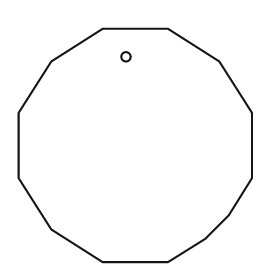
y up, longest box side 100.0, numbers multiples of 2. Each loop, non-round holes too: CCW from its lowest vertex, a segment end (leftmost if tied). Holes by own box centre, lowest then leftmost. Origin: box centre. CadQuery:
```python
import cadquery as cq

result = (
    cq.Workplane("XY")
    .moveTo(-14.0, -50.0)
    .lineTo(14.0, -50.0)
    .lineTo(30.0, -40.0)
    .lineTo(40.0, -30.0)
    .lineTo(50.0, -14.0)
    .lineTo(50.0, 14.0)
    .lineTo(36.0, 36.0)
    .lineTo(14.0, 50.0)
    .lineTo(-14.0, 50.0)
    .lineTo(-36.0, 36.0)
    .lineTo(-50.0, 14.0)
    .lineTo(-50.0, -14.0)
    .lineTo(-36.0, -36.0)
    .close()
    .moveTo(-4.0, 38.0)
    .circle(2.0)
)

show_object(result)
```